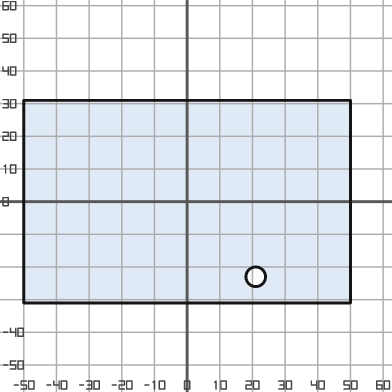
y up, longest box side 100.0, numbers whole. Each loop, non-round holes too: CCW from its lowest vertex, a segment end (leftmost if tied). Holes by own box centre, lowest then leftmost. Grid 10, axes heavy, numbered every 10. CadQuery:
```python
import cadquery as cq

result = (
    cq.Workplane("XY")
    .moveTo(-50.0, -31.0)
    .lineTo(50.0, -31.0)
    .lineTo(50.0, 31.0)
    .lineTo(-50.0, 31.0)
    .close()
    .moveTo(21.0, -23.0)
    .circle(3.0)
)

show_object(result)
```